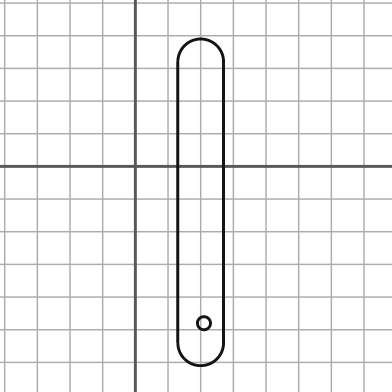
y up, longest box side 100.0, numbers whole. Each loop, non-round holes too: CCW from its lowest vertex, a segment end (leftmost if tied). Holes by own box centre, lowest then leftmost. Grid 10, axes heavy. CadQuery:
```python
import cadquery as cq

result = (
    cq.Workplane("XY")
    .moveTo(13.0, -54.0)
    .threePointArc((20.0, -61.0), (27.0, -54.0))
    .lineTo(27.0, 32.0)
    .threePointArc((20.0, 39.0), (13.0, 32.0))
    .close()
    .moveTo(21.0, -48.0)
    .circle(2.0)
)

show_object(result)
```